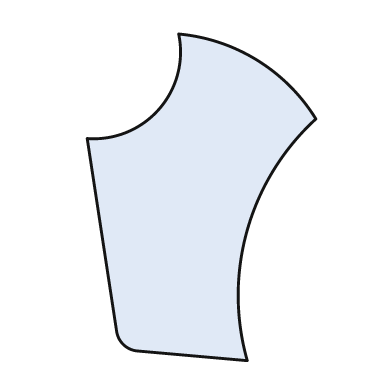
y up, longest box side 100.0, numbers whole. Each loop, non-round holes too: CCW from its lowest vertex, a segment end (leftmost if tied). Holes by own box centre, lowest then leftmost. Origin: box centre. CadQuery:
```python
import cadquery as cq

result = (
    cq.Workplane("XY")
    .moveTo(14.0, -50.0)
    .threePointArc((14.0, -10.0), (35.0, 24.0))
    .threePointArc((17.0, 42.0), (-7.0, 50.0))
    .threePointArc((-13.0, 27.0), (-35.0, 18.0))
    .lineTo(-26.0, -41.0)
    .threePointArc((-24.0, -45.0), (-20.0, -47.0))
    .close()
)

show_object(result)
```